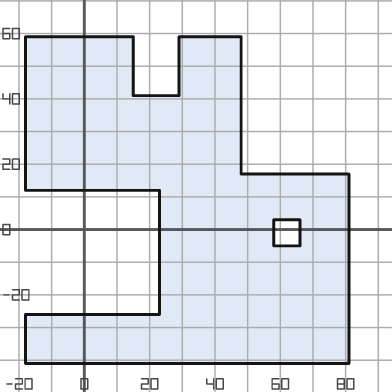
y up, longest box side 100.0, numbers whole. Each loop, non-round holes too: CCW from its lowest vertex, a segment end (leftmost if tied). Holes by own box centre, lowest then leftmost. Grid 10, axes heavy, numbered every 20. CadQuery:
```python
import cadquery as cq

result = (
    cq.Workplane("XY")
    .moveTo(-18.0, -41.0)
    .lineTo(81.0, -41.0)
    .lineTo(81.0, 17.0)
    .lineTo(48.0, 17.0)
    .lineTo(48.0, 59.0)
    .lineTo(29.0, 59.0)
    .lineTo(29.0, 41.0)
    .lineTo(15.0, 41.0)
    .lineTo(15.0, 59.0)
    .lineTo(-18.0, 59.0)
    .lineTo(-18.0, 12.0)
    .lineTo(23.0, 12.0)
    .lineTo(23.0, -26.0)
    .lineTo(-18.0, -26.0)
    .close()
    .moveTo(58.0, -5.0)
    .lineTo(66.0, -5.0)
    .lineTo(66.0, 3.0)
    .lineTo(58.0, 3.0)
    .close()
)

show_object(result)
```